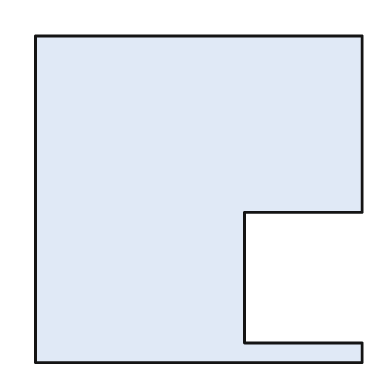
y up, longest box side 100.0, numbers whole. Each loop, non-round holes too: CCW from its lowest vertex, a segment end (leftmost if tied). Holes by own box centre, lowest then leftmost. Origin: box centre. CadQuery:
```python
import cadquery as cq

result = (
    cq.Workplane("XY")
    .moveTo(-50.0, -50.0)
    .lineTo(50.0, -50.0)
    .lineTo(50.0, -44.0)
    .lineTo(14.0, -44.0)
    .lineTo(14.0, -4.0)
    .lineTo(50.0, -4.0)
    .lineTo(50.0, 50.0)
    .lineTo(-50.0, 50.0)
    .close()
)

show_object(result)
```